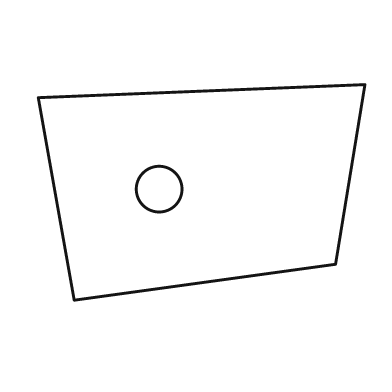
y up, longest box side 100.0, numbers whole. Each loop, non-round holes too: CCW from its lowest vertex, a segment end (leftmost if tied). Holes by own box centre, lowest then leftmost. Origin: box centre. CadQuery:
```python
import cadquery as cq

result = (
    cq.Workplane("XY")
    .moveTo(-39.0, -33.0)
    .lineTo(41.0, -22.0)
    .lineTo(50.0, 33.0)
    .lineTo(-50.0, 29.0)
    .close()
    .moveTo(-13.0, 1.0)
    .circle(7.0)
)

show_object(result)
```